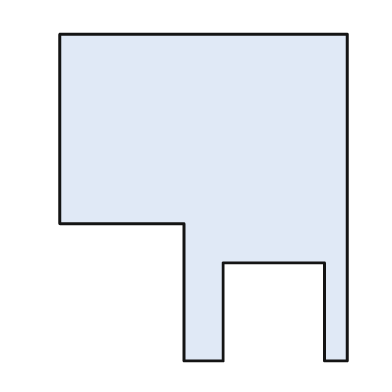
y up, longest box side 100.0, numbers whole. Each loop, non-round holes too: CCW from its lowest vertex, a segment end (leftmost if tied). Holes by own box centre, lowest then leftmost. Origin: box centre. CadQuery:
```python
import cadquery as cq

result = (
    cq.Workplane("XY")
    .moveTo(-6.0, -50.0)
    .lineTo(6.0, -50.0)
    .lineTo(6.0, -20.0)
    .lineTo(37.0, -20.0)
    .lineTo(37.0, -50.0)
    .lineTo(44.0, -50.0)
    .lineTo(44.0, 50.0)
    .lineTo(-44.0, 50.0)
    .lineTo(-44.0, -8.0)
    .lineTo(-6.0, -8.0)
    .close()
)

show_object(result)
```